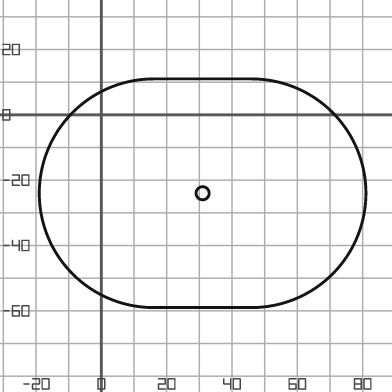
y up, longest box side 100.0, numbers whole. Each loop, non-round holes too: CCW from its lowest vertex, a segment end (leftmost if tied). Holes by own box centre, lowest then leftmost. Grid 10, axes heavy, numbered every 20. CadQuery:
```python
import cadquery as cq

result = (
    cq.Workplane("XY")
    .moveTo(16.0, -59.0)
    .lineTo(46.0, -59.0)
    .threePointArc((81.0, -24.0), (46.0, 11.0))
    .lineTo(16.0, 11.0)
    .threePointArc((-19.0, -24.0), (16.0, -59.0))
    .close()
    .moveTo(31.0, -24.0)
    .circle(2.0)
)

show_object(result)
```